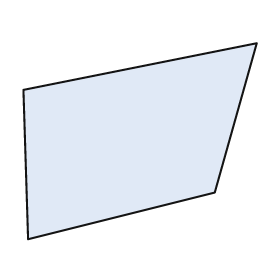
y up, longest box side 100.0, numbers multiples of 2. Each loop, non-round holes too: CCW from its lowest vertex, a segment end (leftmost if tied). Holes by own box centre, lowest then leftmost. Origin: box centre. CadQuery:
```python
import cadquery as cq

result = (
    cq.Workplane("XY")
    .moveTo(-48.0, -42.0)
    .lineTo(32.0, -22.0)
    .lineTo(50.0, 42.0)
    .lineTo(-50.0, 22.0)
    .close()
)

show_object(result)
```